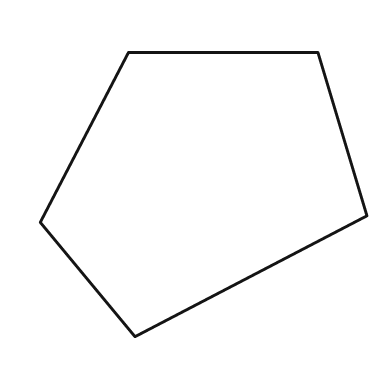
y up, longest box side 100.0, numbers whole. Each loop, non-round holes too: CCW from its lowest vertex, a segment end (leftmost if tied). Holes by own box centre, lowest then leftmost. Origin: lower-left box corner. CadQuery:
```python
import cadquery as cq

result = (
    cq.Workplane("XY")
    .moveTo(29.0, 0.0)
    .lineTo(100.0, 37.0)
    .lineTo(85.0, 87.0)
    .lineTo(27.0, 87.0)
    .lineTo(0.0, 35.0)
    .close()
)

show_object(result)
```